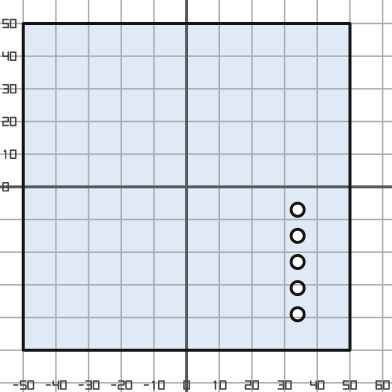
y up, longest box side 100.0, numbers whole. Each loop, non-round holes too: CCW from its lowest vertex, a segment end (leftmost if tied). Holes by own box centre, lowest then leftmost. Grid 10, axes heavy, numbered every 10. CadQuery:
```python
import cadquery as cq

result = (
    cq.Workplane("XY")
    .moveTo(-50.0, -50.0)
    .lineTo(50.0, -50.0)
    .lineTo(50.0, 50.0)
    .lineTo(-50.0, 50.0)
    .close()
    .moveTo(34.0, -39.0)
    .circle(2.0)
    .moveTo(34.0, -31.0)
    .circle(2.0)
    .moveTo(34.0, -23.0)
    .circle(2.0)
    .moveTo(34.0, -15.0)
    .circle(2.0)
    .moveTo(34.0, -7.0)
    .circle(2.0)
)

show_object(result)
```